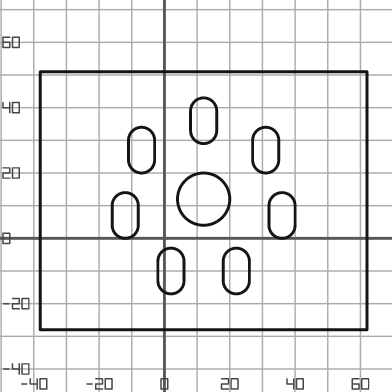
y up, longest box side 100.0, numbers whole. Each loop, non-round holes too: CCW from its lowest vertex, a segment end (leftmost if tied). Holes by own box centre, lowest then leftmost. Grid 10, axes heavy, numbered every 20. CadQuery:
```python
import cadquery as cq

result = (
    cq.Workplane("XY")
    .moveTo(-38.0, -28.0)
    .lineTo(62.0, -28.0)
    .lineTo(62.0, 51.0)
    .lineTo(-38.0, 51.0)
    .close()
    .moveTo(-2.0, -13.0)
    .threePointArc((2.0, -17.0), (6.0, -13.0))
    .lineTo(6.0, -7.0)
    .threePointArc((2.0, -3.0), (-2.0, -7.0))
    .close()
    .moveTo(18.0, -13.0)
    .threePointArc((22.0, -17.0), (26.0, -13.0))
    .lineTo(26.0, -7.0)
    .threePointArc((22.0, -3.0), (18.0, -7.0))
    .close()
    .moveTo(-16.0, 4.0)
    .threePointArc((-12.0, 0.0), (-8.0, 4.0))
    .lineTo(-8.0, 10.0)
    .threePointArc((-12.0, 14.0), (-16.0, 10.0))
    .close()
    .moveTo(32.0, 4.0)
    .threePointArc((36.0, 0.0), (40.0, 4.0))
    .lineTo(40.0, 10.0)
    .threePointArc((36.0, 14.0), (32.0, 10.0))
    .close()
    .moveTo(12.0, 12.0)
    .circle(8.0)
    .moveTo(-11.0, 24.0)
    .threePointArc((-7.0, 20.0), (-3.0, 24.0))
    .lineTo(-3.0, 30.0)
    .threePointArc((-7.0, 34.0), (-11.0, 30.0))
    .close()
    .moveTo(27.0, 24.0)
    .threePointArc((31.0, 20.0), (35.0, 24.0))
    .lineTo(35.0, 30.0)
    .threePointArc((31.0, 34.0), (27.0, 30.0))
    .close()
    .moveTo(8.0, 33.0)
    .threePointArc((12.0, 29.0), (16.0, 33.0))
    .lineTo(16.0, 39.0)
    .threePointArc((12.0, 43.0), (8.0, 39.0))
    .close()
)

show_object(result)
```